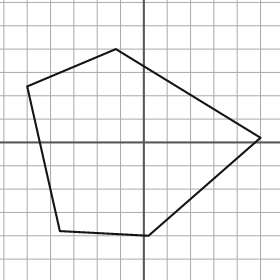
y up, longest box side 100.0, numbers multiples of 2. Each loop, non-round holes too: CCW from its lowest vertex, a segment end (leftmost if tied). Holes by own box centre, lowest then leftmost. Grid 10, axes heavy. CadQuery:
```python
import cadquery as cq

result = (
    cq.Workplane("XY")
    .moveTo(2.0, -40.0)
    .lineTo(50.0, 2.0)
    .lineTo(-12.0, 40.0)
    .lineTo(-50.0, 24.0)
    .lineTo(-36.0, -38.0)
    .close()
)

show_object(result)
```